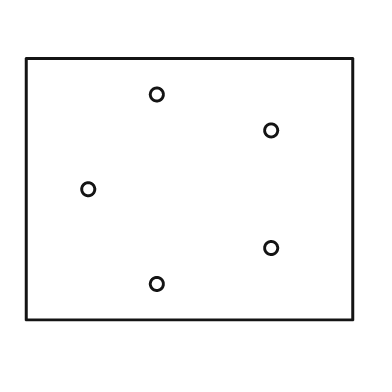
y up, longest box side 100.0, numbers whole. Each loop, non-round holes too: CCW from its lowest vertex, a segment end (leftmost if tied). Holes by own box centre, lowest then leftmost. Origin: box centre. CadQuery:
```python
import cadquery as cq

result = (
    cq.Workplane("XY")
    .moveTo(-50.0, -40.0)
    .lineTo(50.0, -40.0)
    .lineTo(50.0, 40.0)
    .lineTo(-50.0, 40.0)
    .close()
    .moveTo(-10.0, -29.0)
    .circle(2.0)
    .moveTo(25.0, -18.0)
    .circle(2.0)
    .moveTo(-31.0, 0.0)
    .circle(2.0)
    .moveTo(25.0, 18.0)
    .circle(2.0)
    .moveTo(-10.0, 29.0)
    .circle(2.0)
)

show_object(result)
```